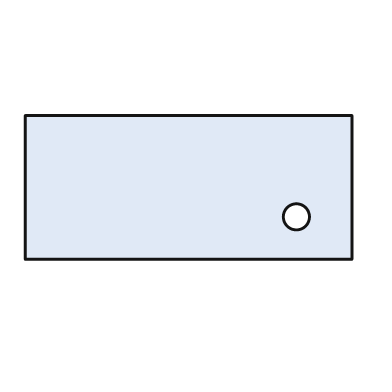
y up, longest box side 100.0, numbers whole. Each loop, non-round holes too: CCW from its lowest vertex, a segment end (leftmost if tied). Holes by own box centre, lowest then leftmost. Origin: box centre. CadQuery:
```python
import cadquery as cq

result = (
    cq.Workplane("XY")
    .moveTo(-50.0, -22.0)
    .lineTo(50.0, -22.0)
    .lineTo(50.0, 22.0)
    .lineTo(-50.0, 22.0)
    .close()
    .moveTo(33.0, -9.0)
    .circle(4.0)
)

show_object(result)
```